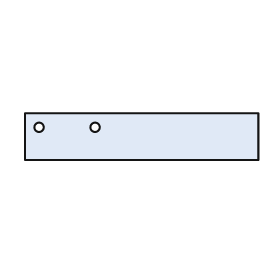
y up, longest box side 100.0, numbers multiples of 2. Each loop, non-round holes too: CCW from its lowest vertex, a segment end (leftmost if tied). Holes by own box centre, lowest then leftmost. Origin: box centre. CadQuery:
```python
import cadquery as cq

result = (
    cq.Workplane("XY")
    .moveTo(-50.0, -10.0)
    .lineTo(50.0, -10.0)
    .lineTo(50.0, 10.0)
    .lineTo(-50.0, 10.0)
    .close()
    .moveTo(-44.0, 4.0)
    .circle(2.0)
    .moveTo(-20.0, 4.0)
    .circle(2.0)
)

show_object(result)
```